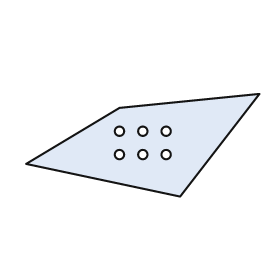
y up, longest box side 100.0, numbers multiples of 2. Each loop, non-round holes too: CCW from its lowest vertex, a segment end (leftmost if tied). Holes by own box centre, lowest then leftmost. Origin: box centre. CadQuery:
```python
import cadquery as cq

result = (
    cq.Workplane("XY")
    .moveTo(16.0, -22.0)
    .lineTo(50.0, 22.0)
    .lineTo(-10.0, 16.0)
    .lineTo(-50.0, -8.0)
    .close()
    .moveTo(-10.0, -4.0)
    .circle(2.0)
    .moveTo(0.0, -4.0)
    .circle(2.0)
    .moveTo(10.0, -4.0)
    .circle(2.0)
    .moveTo(-10.0, 6.0)
    .circle(2.0)
    .moveTo(0.0, 6.0)
    .circle(2.0)
    .moveTo(10.0, 6.0)
    .circle(2.0)
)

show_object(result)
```